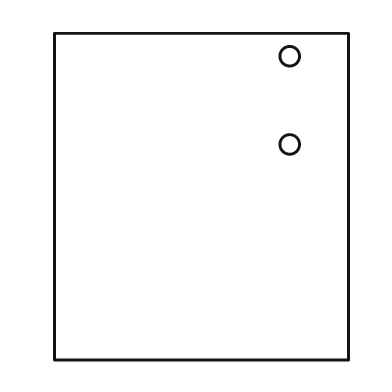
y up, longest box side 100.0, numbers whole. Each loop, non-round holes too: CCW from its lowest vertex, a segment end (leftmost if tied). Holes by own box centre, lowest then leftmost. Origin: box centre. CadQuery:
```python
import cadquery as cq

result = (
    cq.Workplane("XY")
    .moveTo(-45.0, -50.0)
    .lineTo(45.0, -50.0)
    .lineTo(45.0, 50.0)
    .lineTo(-45.0, 50.0)
    .close()
    .moveTo(27.0, 16.0)
    .circle(3.0)
    .moveTo(27.0, 43.0)
    .circle(3.0)
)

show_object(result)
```